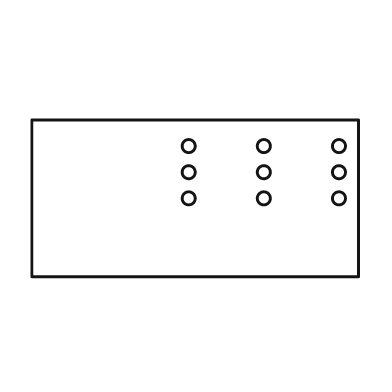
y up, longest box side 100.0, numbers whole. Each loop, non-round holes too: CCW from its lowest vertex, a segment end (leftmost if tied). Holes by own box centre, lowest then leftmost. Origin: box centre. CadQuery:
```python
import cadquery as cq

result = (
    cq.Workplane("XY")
    .moveTo(-50.0, -24.0)
    .lineTo(50.0, -24.0)
    .lineTo(50.0, 24.0)
    .lineTo(-50.0, 24.0)
    .close()
    .moveTo(-2.0, 0.0)
    .circle(2.0)
    .moveTo(21.0, 0.0)
    .circle(2.0)
    .moveTo(44.0, 0.0)
    .circle(2.0)
    .moveTo(-2.0, 8.0)
    .circle(2.0)
    .moveTo(21.0, 8.0)
    .circle(2.0)
    .moveTo(44.0, 8.0)
    .circle(2.0)
    .moveTo(-2.0, 16.0)
    .circle(2.0)
    .moveTo(21.0, 16.0)
    .circle(2.0)
    .moveTo(44.0, 16.0)
    .circle(2.0)
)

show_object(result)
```